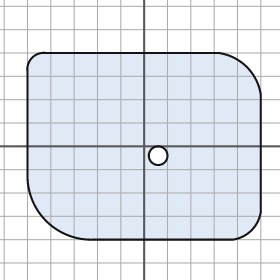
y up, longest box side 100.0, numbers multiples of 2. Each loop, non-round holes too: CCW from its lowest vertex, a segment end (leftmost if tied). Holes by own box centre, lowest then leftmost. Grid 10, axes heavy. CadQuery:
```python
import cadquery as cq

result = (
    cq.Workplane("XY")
    .moveTo(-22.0, -40.0)
    .lineTo(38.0, -40.0)
    .threePointArc((46.0, -36.0), (50.0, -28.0))
    .lineTo(50.0, 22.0)
    .threePointArc((44.0, 34.0), (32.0, 40.0))
    .lineTo(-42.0, 40.0)
    .threePointArc((-48.0, 38.0), (-50.0, 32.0))
    .lineTo(-50.0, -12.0)
    .threePointArc((-42.0, -32.0), (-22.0, -40.0))
    .close()
    .moveTo(6.0, -4.0)
    .circle(4.0)
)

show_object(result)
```